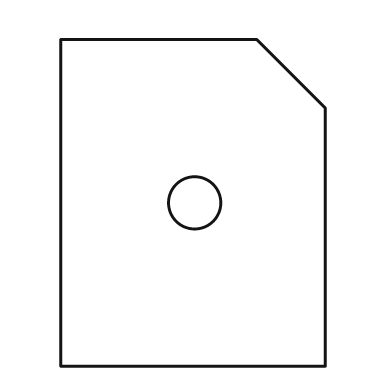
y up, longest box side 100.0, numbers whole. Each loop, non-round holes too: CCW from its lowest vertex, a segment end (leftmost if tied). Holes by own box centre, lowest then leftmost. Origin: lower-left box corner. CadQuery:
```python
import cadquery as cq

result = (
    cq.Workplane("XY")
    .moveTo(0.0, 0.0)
    .lineTo(81.0, 0.0)
    .lineTo(81.0, 79.0)
    .lineTo(60.0, 100.0)
    .lineTo(0.0, 100.0)
    .close()
    .moveTo(41.0, 50.0)
    .circle(8.0)
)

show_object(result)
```